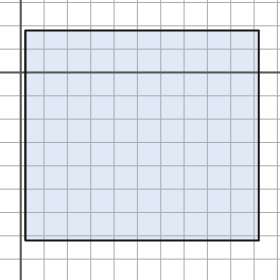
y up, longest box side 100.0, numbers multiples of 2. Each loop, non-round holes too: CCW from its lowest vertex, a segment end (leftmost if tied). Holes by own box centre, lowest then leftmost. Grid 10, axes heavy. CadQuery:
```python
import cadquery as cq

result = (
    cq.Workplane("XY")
    .moveTo(2.0, -72.0)
    .lineTo(102.0, -72.0)
    .lineTo(102.0, 18.0)
    .lineTo(2.0, 18.0)
    .close()
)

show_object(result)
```